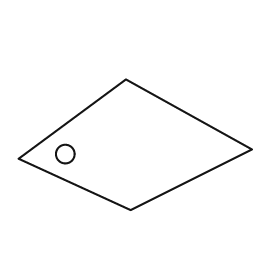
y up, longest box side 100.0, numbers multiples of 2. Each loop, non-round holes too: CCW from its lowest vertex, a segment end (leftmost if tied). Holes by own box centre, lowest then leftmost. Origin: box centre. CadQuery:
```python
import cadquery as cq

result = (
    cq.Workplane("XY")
    .moveTo(-2.0, -28.0)
    .lineTo(50.0, -2.0)
    .lineTo(-4.0, 28.0)
    .lineTo(-50.0, -6.0)
    .close()
    .moveTo(-30.0, -4.0)
    .circle(4.0)
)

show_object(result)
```